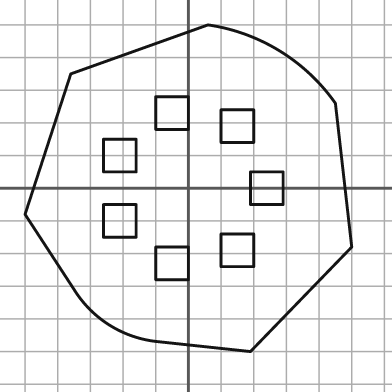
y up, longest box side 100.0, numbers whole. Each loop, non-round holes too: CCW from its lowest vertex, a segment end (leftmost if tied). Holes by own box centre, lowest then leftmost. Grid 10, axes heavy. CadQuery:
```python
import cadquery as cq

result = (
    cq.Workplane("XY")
    .moveTo(19.0, -50.0)
    .lineTo(50.0, -18.0)
    .lineTo(45.0, 26.0)
    .threePointArc((28.0, 42.0), (6.0, 50.0))
    .lineTo(-36.0, 35.0)
    .lineTo(-50.0, -8.0)
    .lineTo(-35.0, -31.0)
    .threePointArc((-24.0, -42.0), (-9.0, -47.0))
    .close()
    .moveTo(-10.0, -28.0)
    .lineTo(0.0, -28.0)
    .lineTo(0.0, -18.0)
    .lineTo(-10.0, -18.0)
    .close()
    .moveTo(10.0, -24.0)
    .lineTo(20.0, -24.0)
    .lineTo(20.0, -14.0)
    .lineTo(10.0, -14.0)
    .close()
    .moveTo(-26.0, -15.0)
    .lineTo(-16.0, -15.0)
    .lineTo(-16.0, -5.0)
    .lineTo(-26.0, -5.0)
    .close()
    .moveTo(19.0, -5.0)
    .lineTo(29.0, -5.0)
    .lineTo(29.0, 5.0)
    .lineTo(19.0, 5.0)
    .close()
    .moveTo(-26.0, 5.0)
    .lineTo(-16.0, 5.0)
    .lineTo(-16.0, 15.0)
    .lineTo(-26.0, 15.0)
    .close()
    .moveTo(10.0, 14.0)
    .lineTo(20.0, 14.0)
    .lineTo(20.0, 24.0)
    .lineTo(10.0, 24.0)
    .close()
    .moveTo(-10.0, 18.0)
    .lineTo(0.0, 18.0)
    .lineTo(0.0, 28.0)
    .lineTo(-10.0, 28.0)
    .close()
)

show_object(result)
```